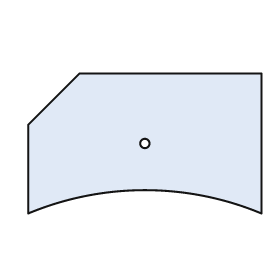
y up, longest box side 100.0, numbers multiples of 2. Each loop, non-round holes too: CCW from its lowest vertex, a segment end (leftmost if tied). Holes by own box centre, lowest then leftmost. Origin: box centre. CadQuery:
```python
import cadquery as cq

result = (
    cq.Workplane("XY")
    .moveTo(-50.0, -30.0)
    .threePointArc((0.0, -20.0), (50.0, -30.0))
    .lineTo(50.0, 30.0)
    .lineTo(-28.0, 30.0)
    .lineTo(-50.0, 8.0)
    .close()
    .moveTo(0.0, 0.0)
    .circle(2.0)
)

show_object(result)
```